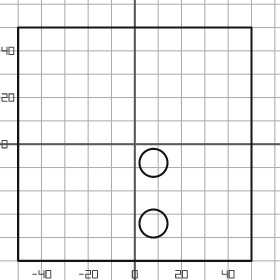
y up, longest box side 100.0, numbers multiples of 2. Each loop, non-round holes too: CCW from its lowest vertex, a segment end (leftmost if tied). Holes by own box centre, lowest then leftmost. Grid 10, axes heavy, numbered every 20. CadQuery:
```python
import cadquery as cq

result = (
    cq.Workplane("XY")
    .moveTo(-50.0, -50.0)
    .lineTo(50.0, -50.0)
    .lineTo(50.0, 50.0)
    .lineTo(-50.0, 50.0)
    .close()
    .moveTo(8.0, -34.0)
    .circle(6.0)
    .moveTo(8.0, -8.0)
    .circle(6.0)
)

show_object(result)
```